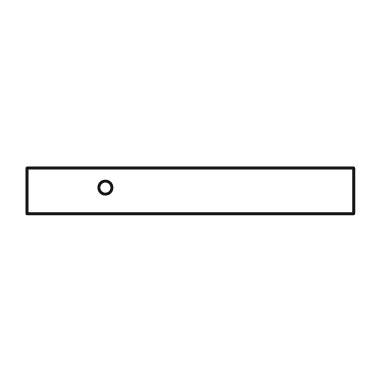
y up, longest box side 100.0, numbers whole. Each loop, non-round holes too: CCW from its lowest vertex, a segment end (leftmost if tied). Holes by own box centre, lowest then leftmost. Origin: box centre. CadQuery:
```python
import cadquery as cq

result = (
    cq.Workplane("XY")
    .moveTo(-50.0, -7.0)
    .lineTo(50.0, -7.0)
    .lineTo(50.0, 7.0)
    .lineTo(-50.0, 7.0)
    .close()
    .moveTo(-26.0, 1.0)
    .circle(2.0)
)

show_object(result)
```